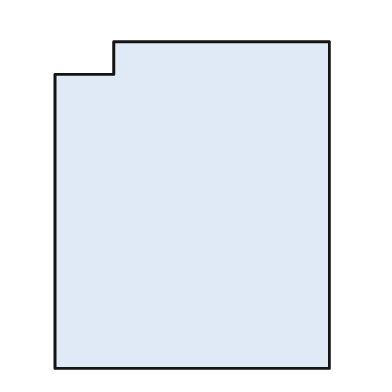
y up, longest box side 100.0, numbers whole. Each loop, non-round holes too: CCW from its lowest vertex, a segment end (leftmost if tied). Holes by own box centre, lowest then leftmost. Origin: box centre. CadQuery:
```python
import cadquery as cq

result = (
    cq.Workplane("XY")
    .moveTo(-42.0, -50.0)
    .lineTo(42.0, -50.0)
    .lineTo(42.0, 50.0)
    .lineTo(-24.0, 50.0)
    .lineTo(-24.0, 40.0)
    .lineTo(-42.0, 40.0)
    .close()
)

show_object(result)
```